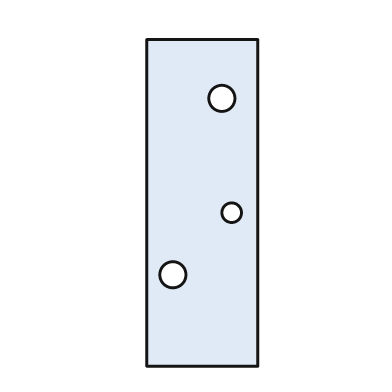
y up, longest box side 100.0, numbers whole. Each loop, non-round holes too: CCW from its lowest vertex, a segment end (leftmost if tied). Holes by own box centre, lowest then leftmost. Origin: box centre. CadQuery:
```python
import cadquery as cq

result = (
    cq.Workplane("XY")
    .moveTo(-17.0, -50.0)
    .lineTo(17.0, -50.0)
    .lineTo(17.0, 50.0)
    .lineTo(-17.0, 50.0)
    .close()
    .moveTo(-9.0, -22.0)
    .circle(4.0)
    .moveTo(9.0, -3.0)
    .circle(3.0)
    .moveTo(6.0, 32.0)
    .circle(4.0)
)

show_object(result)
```